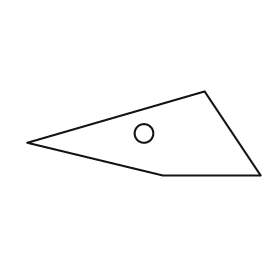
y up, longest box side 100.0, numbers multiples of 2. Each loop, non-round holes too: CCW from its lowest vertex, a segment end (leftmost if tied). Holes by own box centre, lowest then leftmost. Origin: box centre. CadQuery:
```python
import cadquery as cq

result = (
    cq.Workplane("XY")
    .moveTo(8.0, -18.0)
    .lineTo(50.0, -18.0)
    .lineTo(26.0, 18.0)
    .lineTo(-50.0, -4.0)
    .close()
    .moveTo(0.0, 0.0)
    .circle(4.0)
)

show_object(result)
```